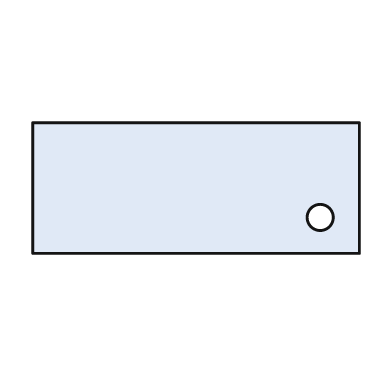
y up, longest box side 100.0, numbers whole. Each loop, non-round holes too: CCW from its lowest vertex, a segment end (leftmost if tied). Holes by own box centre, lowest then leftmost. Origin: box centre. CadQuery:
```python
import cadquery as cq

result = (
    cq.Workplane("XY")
    .moveTo(-50.0, -20.0)
    .lineTo(50.0, -20.0)
    .lineTo(50.0, 20.0)
    .lineTo(-50.0, 20.0)
    .close()
    .moveTo(38.0, -9.0)
    .circle(4.0)
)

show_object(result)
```